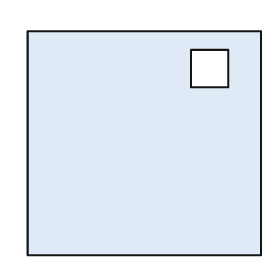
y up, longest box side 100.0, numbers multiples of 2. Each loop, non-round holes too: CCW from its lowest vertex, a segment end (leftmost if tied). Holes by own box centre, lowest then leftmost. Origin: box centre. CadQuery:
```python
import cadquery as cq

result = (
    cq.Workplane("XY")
    .moveTo(-50.0, -48.0)
    .lineTo(50.0, -48.0)
    .lineTo(50.0, 48.0)
    .lineTo(-50.0, 48.0)
    .close()
    .moveTo(20.0, 24.0)
    .lineTo(36.0, 24.0)
    .lineTo(36.0, 40.0)
    .lineTo(20.0, 40.0)
    .close()
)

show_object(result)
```